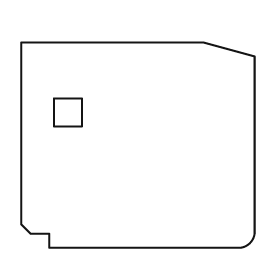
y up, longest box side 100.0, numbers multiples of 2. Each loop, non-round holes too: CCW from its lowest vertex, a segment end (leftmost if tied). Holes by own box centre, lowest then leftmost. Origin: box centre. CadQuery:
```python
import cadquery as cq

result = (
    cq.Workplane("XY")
    .moveTo(-38.0, -44.0)
    .lineTo(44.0, -44.0)
    .threePointArc((48.0, -42.0), (50.0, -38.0))
    .lineTo(50.0, 38.0)
    .lineTo(28.0, 44.0)
    .lineTo(-50.0, 44.0)
    .lineTo(-50.0, -34.0)
    .lineTo(-46.0, -38.0)
    .lineTo(-38.0, -38.0)
    .close()
    .moveTo(-36.0, 8.0)
    .lineTo(-24.0, 8.0)
    .lineTo(-24.0, 20.0)
    .lineTo(-36.0, 20.0)
    .close()
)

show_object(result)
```